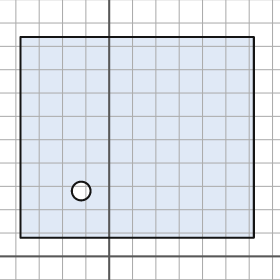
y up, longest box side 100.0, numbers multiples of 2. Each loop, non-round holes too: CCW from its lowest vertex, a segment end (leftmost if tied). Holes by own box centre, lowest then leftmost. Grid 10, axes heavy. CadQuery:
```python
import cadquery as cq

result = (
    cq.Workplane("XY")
    .moveTo(-38.0, 8.0)
    .lineTo(62.0, 8.0)
    .lineTo(62.0, 94.0)
    .lineTo(-38.0, 94.0)
    .close()
    .moveTo(-12.0, 28.0)
    .circle(4.0)
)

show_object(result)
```